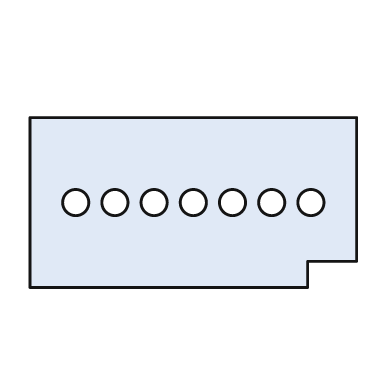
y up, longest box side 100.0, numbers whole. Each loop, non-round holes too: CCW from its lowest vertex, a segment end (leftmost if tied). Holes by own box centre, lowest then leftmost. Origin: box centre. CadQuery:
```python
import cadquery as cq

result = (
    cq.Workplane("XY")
    .moveTo(-50.0, -26.0)
    .lineTo(35.0, -26.0)
    .lineTo(35.0, -18.0)
    .lineTo(50.0, -18.0)
    .lineTo(50.0, 26.0)
    .lineTo(-50.0, 26.0)
    .close()
    .moveTo(-36.0, 0.0)
    .circle(4.0)
    .moveTo(-24.0, 0.0)
    .circle(4.0)
    .moveTo(-12.0, 0.0)
    .circle(4.0)
    .moveTo(0.0, 0.0)
    .circle(4.0)
    .moveTo(12.0, 0.0)
    .circle(4.0)
    .moveTo(24.0, 0.0)
    .circle(4.0)
    .moveTo(36.0, 0.0)
    .circle(4.0)
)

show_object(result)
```